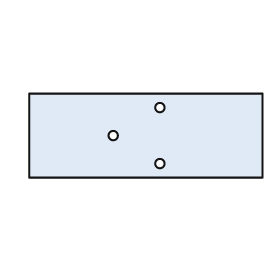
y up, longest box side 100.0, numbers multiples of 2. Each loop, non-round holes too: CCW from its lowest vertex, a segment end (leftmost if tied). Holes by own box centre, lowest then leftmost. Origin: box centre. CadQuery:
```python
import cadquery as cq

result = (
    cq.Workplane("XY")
    .moveTo(-50.0, -18.0)
    .lineTo(50.0, -18.0)
    .lineTo(50.0, 18.0)
    .lineTo(-50.0, 18.0)
    .close()
    .moveTo(6.0, -12.0)
    .circle(2.0)
    .moveTo(-14.0, 0.0)
    .circle(2.0)
    .moveTo(6.0, 12.0)
    .circle(2.0)
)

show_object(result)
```